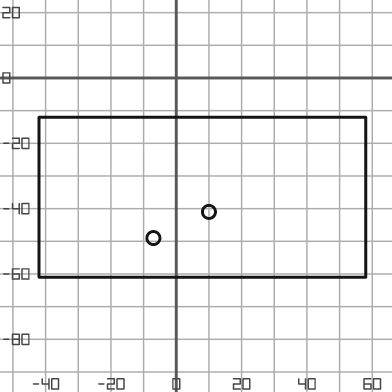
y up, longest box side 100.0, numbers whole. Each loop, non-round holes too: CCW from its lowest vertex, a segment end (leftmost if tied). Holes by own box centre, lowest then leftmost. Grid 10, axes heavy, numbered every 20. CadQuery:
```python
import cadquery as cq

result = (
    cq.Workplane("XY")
    .moveTo(-42.0, -61.0)
    .lineTo(58.0, -61.0)
    .lineTo(58.0, -12.0)
    .lineTo(-42.0, -12.0)
    .close()
    .moveTo(-7.0, -49.0)
    .circle(2.0)
    .moveTo(10.0, -41.0)
    .circle(2.0)
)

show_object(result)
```